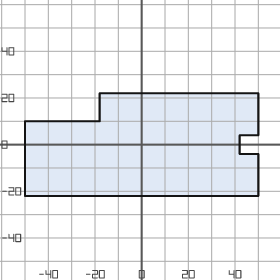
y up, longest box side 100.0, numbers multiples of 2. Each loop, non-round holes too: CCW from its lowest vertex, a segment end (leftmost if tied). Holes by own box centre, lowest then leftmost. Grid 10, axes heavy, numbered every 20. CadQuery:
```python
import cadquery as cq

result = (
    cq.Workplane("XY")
    .moveTo(-50.0, -22.0)
    .lineTo(50.0, -22.0)
    .lineTo(50.0, -4.0)
    .lineTo(42.0, -4.0)
    .lineTo(42.0, 4.0)
    .lineTo(50.0, 4.0)
    .lineTo(50.0, 22.0)
    .lineTo(-18.0, 22.0)
    .lineTo(-18.0, 10.0)
    .lineTo(-50.0, 10.0)
    .close()
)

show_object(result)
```